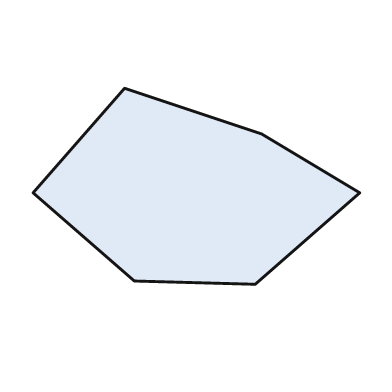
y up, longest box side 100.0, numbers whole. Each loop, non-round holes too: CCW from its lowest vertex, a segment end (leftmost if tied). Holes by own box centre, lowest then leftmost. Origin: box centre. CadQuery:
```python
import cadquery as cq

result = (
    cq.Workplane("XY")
    .moveTo(18.0, -30.0)
    .lineTo(50.0, -2.0)
    .lineTo(20.0, 16.0)
    .lineTo(-22.0, 30.0)
    .lineTo(-50.0, -2.0)
    .lineTo(-19.0, -29.0)
    .close()
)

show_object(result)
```